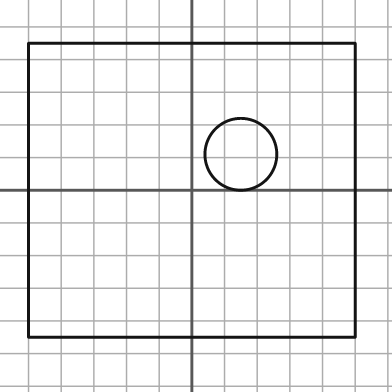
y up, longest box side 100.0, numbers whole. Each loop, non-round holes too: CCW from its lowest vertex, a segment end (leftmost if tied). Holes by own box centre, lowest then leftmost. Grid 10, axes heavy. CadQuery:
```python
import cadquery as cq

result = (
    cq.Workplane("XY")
    .moveTo(-50.0, -45.0)
    .lineTo(50.0, -45.0)
    .lineTo(50.0, 45.0)
    .lineTo(-50.0, 45.0)
    .close()
    .moveTo(15.0, 11.0)
    .circle(11.0)
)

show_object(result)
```